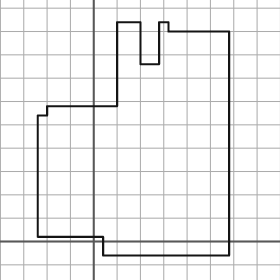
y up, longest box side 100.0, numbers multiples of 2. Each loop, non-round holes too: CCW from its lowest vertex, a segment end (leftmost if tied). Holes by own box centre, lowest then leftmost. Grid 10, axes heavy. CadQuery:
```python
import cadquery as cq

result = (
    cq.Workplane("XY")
    .moveTo(4.0, -6.0)
    .lineTo(58.0, -6.0)
    .lineTo(58.0, 90.0)
    .lineTo(32.0, 90.0)
    .lineTo(32.0, 94.0)
    .lineTo(28.0, 94.0)
    .lineTo(28.0, 76.0)
    .lineTo(20.0, 76.0)
    .lineTo(20.0, 94.0)
    .lineTo(10.0, 94.0)
    .lineTo(10.0, 58.0)
    .lineTo(-20.0, 58.0)
    .lineTo(-20.0, 54.0)
    .lineTo(-24.0, 54.0)
    .lineTo(-24.0, 2.0)
    .lineTo(4.0, 2.0)
    .close()
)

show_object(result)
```